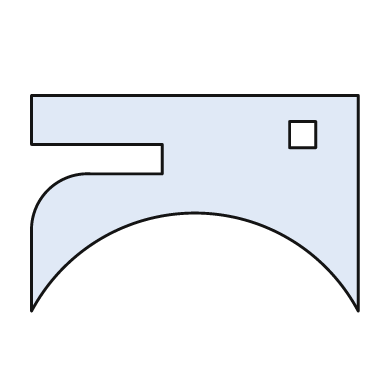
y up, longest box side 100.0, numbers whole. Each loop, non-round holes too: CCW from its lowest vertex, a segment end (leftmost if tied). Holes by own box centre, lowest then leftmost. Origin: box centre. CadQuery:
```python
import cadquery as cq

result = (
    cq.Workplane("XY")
    .moveTo(-50.0, -33.0)
    .threePointArc((0.0, -3.0), (50.0, -33.0))
    .lineTo(50.0, 33.0)
    .lineTo(-50.0, 33.0)
    .lineTo(-50.0, 18.0)
    .lineTo(-10.0, 18.0)
    .lineTo(-10.0, 9.0)
    .lineTo(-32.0, 9.0)
    .threePointArc((-45.0, 4.0), (-50.0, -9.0))
    .close()
    .moveTo(29.0, 17.0)
    .lineTo(37.0, 17.0)
    .lineTo(37.0, 25.0)
    .lineTo(29.0, 25.0)
    .close()
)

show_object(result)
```